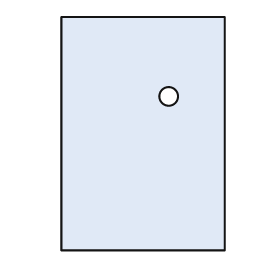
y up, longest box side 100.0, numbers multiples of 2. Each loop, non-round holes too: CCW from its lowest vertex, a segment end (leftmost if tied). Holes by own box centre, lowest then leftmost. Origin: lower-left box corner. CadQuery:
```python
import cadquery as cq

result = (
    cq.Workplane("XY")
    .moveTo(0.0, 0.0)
    .lineTo(70.0, 0.0)
    .lineTo(70.0, 100.0)
    .lineTo(0.0, 100.0)
    .close()
    .moveTo(46.0, 66.0)
    .circle(4.0)
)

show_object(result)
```